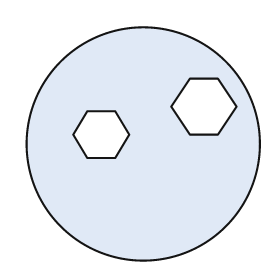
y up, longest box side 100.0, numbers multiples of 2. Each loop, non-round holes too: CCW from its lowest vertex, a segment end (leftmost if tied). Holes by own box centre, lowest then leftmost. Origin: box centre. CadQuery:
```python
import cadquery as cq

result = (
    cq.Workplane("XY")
    .moveTo(0.0, 0.0)
    .circle(50.0)
    .moveTo(-24.0, -6.0)
    .lineTo(-12.0, -6.0)
    .lineTo(-6.0, 4.0)
    .lineTo(-12.0, 14.0)
    .lineTo(-24.0, 14.0)
    .lineTo(-30.0, 4.0)
    .close()
    .moveTo(20.0, 4.0)
    .lineTo(32.0, 4.0)
    .lineTo(40.0, 16.0)
    .lineTo(32.0, 28.0)
    .lineTo(20.0, 28.0)
    .lineTo(12.0, 16.0)
    .close()
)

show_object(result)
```